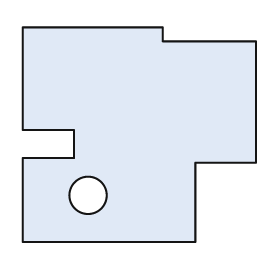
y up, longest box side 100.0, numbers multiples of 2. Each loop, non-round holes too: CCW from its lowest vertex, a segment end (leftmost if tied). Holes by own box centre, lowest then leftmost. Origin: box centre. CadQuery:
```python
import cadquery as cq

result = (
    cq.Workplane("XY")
    .moveTo(-50.0, -46.0)
    .lineTo(24.0, -46.0)
    .lineTo(24.0, -12.0)
    .lineTo(50.0, -12.0)
    .lineTo(50.0, 40.0)
    .lineTo(10.0, 40.0)
    .lineTo(10.0, 46.0)
    .lineTo(-50.0, 46.0)
    .lineTo(-50.0, 2.0)
    .lineTo(-28.0, 2.0)
    .lineTo(-28.0, -10.0)
    .lineTo(-50.0, -10.0)
    .close()
    .moveTo(-22.0, -26.0)
    .circle(8.0)
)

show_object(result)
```